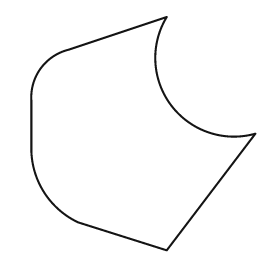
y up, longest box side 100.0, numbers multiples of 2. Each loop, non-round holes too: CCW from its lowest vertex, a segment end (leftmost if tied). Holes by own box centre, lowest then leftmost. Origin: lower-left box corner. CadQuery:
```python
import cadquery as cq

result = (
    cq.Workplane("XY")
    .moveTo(58.0, 0.0)
    .lineTo(96.0, 50.0)
    .threePointArc((60.0, 62.0), (58.0, 100.0))
    .lineTo(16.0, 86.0)
    .threePointArc((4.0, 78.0), (0.0, 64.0))
    .lineTo(0.0, 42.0)
    .threePointArc((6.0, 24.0), (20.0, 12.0))
    .close()
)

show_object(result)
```